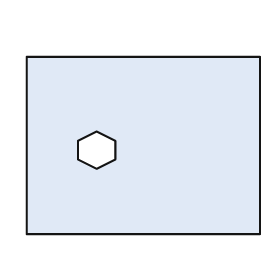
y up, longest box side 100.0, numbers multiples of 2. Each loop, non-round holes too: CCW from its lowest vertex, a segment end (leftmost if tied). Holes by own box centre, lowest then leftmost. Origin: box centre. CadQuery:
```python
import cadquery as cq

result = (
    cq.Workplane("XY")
    .moveTo(-50.0, -38.0)
    .lineTo(50.0, -38.0)
    .lineTo(50.0, 38.0)
    .lineTo(-50.0, 38.0)
    .close()
    .moveTo(-20.0, -10.0)
    .lineTo(-12.0, -6.0)
    .lineTo(-12.0, 2.0)
    .lineTo(-20.0, 6.0)
    .lineTo(-28.0, 2.0)
    .lineTo(-28.0, -6.0)
    .close()
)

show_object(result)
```